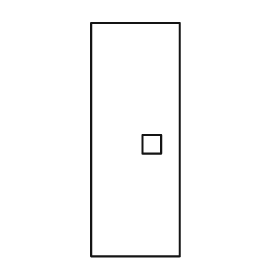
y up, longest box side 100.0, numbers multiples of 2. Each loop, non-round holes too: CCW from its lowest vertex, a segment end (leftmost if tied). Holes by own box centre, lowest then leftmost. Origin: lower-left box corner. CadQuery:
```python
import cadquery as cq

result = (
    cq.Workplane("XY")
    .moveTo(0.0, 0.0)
    .lineTo(38.0, 0.0)
    .lineTo(38.0, 100.0)
    .lineTo(0.0, 100.0)
    .close()
    .moveTo(22.0, 44.0)
    .lineTo(30.0, 44.0)
    .lineTo(30.0, 52.0)
    .lineTo(22.0, 52.0)
    .close()
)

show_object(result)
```